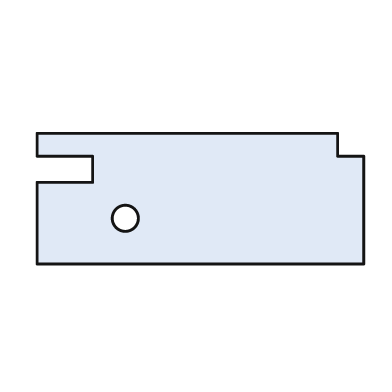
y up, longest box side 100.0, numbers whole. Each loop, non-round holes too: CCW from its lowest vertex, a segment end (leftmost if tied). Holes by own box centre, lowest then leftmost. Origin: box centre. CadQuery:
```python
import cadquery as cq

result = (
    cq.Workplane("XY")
    .moveTo(-50.0, -20.0)
    .lineTo(50.0, -20.0)
    .lineTo(50.0, 13.0)
    .lineTo(42.0, 13.0)
    .lineTo(42.0, 20.0)
    .lineTo(-50.0, 20.0)
    .lineTo(-50.0, 13.0)
    .lineTo(-33.0, 13.0)
    .lineTo(-33.0, 5.0)
    .lineTo(-50.0, 5.0)
    .close()
    .moveTo(-23.0, -6.0)
    .circle(4.0)
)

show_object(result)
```